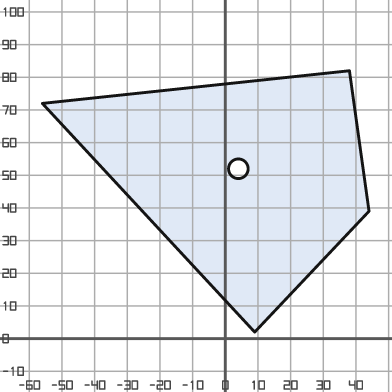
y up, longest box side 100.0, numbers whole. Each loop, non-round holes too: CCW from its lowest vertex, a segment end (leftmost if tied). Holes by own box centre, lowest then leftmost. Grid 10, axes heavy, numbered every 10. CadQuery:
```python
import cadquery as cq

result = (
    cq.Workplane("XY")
    .moveTo(9.0, 2.0)
    .lineTo(44.0, 39.0)
    .lineTo(38.0, 82.0)
    .lineTo(-56.0, 72.0)
    .close()
    .moveTo(4.0, 52.0)
    .circle(3.0)
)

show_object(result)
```